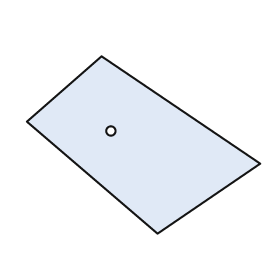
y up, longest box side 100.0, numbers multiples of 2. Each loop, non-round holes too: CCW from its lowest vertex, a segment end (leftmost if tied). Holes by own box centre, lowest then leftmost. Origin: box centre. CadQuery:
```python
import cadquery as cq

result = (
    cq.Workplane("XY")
    .moveTo(6.0, -38.0)
    .lineTo(50.0, -8.0)
    .lineTo(-18.0, 38.0)
    .lineTo(-50.0, 10.0)
    .close()
    .moveTo(-14.0, 6.0)
    .circle(2.0)
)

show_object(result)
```